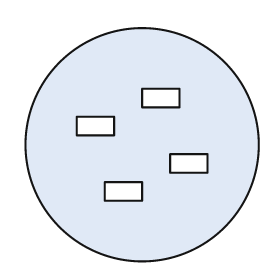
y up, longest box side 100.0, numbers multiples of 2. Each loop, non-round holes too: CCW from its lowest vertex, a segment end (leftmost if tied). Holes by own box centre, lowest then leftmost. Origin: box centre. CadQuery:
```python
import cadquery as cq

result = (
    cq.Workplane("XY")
    .moveTo(0.0, 0.0)
    .circle(50.0)
    .moveTo(-16.0, -24.0)
    .lineTo(0.0, -24.0)
    .lineTo(0.0, -16.0)
    .lineTo(-16.0, -16.0)
    .close()
    .moveTo(12.0, -12.0)
    .lineTo(28.0, -12.0)
    .lineTo(28.0, -4.0)
    .lineTo(12.0, -4.0)
    .close()
    .moveTo(-28.0, 4.0)
    .lineTo(-12.0, 4.0)
    .lineTo(-12.0, 12.0)
    .lineTo(-28.0, 12.0)
    .close()
    .moveTo(0.0, 16.0)
    .lineTo(16.0, 16.0)
    .lineTo(16.0, 24.0)
    .lineTo(0.0, 24.0)
    .close()
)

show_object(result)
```